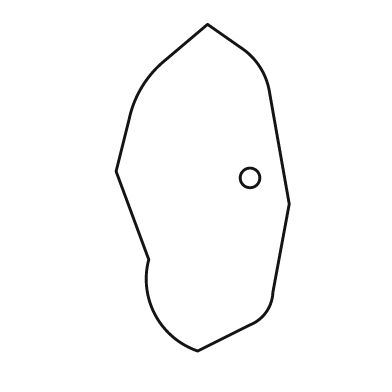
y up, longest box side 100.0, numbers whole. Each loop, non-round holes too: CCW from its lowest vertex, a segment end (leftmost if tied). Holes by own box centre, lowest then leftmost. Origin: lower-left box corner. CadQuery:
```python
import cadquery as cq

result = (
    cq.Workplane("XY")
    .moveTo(25.0, 0.0)
    .lineTo(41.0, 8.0)
    .threePointArc((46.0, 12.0), (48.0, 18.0))
    .lineTo(53.0, 45.0)
    .lineTo(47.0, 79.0)
    .threePointArc((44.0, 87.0), (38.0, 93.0))
    .lineTo(28.0, 100.0)
    .lineTo(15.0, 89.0)
    .threePointArc((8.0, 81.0), (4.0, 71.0))
    .lineTo(0.0, 55.0)
    .lineTo(10.0, 28.0)
    .threePointArc((12.0, 11.0), (25.0, 0.0))
    .close()
    .moveTo(41.0, 53.0)
    .circle(3.0)
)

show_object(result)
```